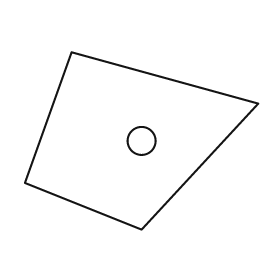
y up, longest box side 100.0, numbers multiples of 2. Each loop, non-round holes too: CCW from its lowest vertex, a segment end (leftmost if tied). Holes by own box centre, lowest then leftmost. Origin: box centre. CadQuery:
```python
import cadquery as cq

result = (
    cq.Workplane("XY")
    .moveTo(0.0, -38.0)
    .lineTo(50.0, 16.0)
    .lineTo(-30.0, 38.0)
    .lineTo(-50.0, -18.0)
    .close()
    .moveTo(0.0, 0.0)
    .circle(6.0)
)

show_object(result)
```